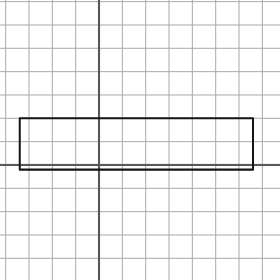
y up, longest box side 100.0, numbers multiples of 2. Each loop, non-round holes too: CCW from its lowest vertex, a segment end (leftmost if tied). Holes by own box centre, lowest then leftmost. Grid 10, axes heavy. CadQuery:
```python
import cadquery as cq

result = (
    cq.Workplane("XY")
    .moveTo(-34.0, -2.0)
    .lineTo(66.0, -2.0)
    .lineTo(66.0, 20.0)
    .lineTo(-34.0, 20.0)
    .close()
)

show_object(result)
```